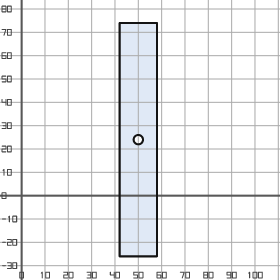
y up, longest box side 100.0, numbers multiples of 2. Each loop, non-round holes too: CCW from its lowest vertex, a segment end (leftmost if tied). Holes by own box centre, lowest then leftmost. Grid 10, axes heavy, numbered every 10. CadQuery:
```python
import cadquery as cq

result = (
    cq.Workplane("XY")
    .moveTo(42.0, -26.0)
    .lineTo(58.0, -26.0)
    .lineTo(58.0, 74.0)
    .lineTo(42.0, 74.0)
    .close()
    .moveTo(50.0, 24.0)
    .circle(2.0)
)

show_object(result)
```